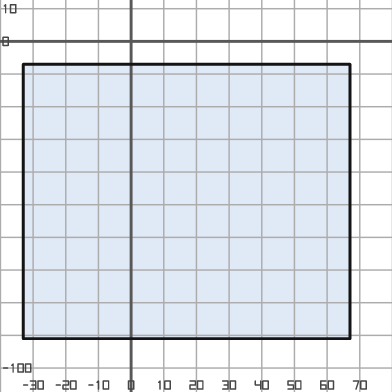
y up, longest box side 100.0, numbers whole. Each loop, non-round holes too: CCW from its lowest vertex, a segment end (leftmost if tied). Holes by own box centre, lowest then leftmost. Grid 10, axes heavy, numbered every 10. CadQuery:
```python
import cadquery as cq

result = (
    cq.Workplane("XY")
    .moveTo(-33.0, -91.0)
    .lineTo(67.0, -91.0)
    .lineTo(67.0, -7.0)
    .lineTo(-33.0, -7.0)
    .close()
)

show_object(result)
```